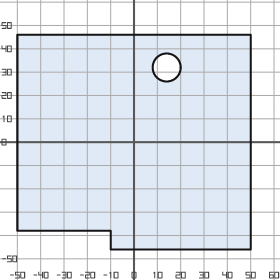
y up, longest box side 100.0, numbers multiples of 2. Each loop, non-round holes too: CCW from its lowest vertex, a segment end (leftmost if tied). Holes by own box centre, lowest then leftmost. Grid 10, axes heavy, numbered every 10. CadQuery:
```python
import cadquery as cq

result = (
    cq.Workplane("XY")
    .moveTo(-10.0, -46.0)
    .lineTo(50.0, -46.0)
    .lineTo(50.0, 46.0)
    .lineTo(-50.0, 46.0)
    .lineTo(-50.0, -38.0)
    .lineTo(-10.0, -38.0)
    .close()
    .moveTo(14.0, 32.0)
    .circle(6.0)
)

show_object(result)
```